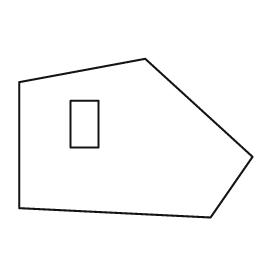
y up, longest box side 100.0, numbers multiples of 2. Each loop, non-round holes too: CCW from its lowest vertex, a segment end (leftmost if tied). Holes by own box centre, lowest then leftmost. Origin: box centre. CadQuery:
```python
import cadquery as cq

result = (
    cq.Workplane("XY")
    .moveTo(32.0, -34.0)
    .lineTo(50.0, -8.0)
    .lineTo(4.0, 34.0)
    .lineTo(-50.0, 24.0)
    .lineTo(-50.0, -30.0)
    .close()
    .moveTo(-28.0, -4.0)
    .lineTo(-16.0, -4.0)
    .lineTo(-16.0, 16.0)
    .lineTo(-28.0, 16.0)
    .close()
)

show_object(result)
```